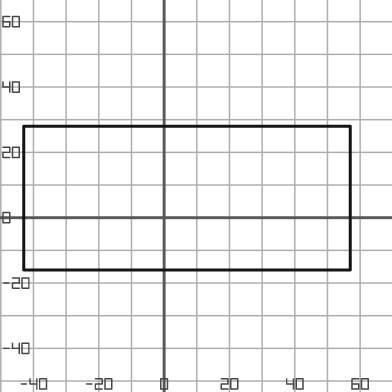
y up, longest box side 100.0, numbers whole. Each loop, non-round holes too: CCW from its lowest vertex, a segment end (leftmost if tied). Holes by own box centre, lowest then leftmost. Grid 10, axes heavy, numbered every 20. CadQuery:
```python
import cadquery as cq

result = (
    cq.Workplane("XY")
    .moveTo(-43.0, -16.0)
    .lineTo(57.0, -16.0)
    .lineTo(57.0, 28.0)
    .lineTo(-43.0, 28.0)
    .close()
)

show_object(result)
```